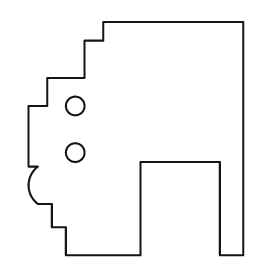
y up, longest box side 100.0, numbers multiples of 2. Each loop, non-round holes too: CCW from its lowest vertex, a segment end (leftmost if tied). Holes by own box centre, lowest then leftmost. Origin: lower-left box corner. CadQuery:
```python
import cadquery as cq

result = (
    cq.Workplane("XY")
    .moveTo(16.0, 0.0)
    .lineTo(48.0, 0.0)
    .lineTo(48.0, 40.0)
    .lineTo(82.0, 40.0)
    .lineTo(82.0, 0.0)
    .lineTo(92.0, 0.0)
    .lineTo(92.0, 100.0)
    .lineTo(32.0, 100.0)
    .lineTo(32.0, 92.0)
    .lineTo(24.0, 92.0)
    .lineTo(24.0, 76.0)
    .lineTo(8.0, 76.0)
    .lineTo(8.0, 64.0)
    .lineTo(0.0, 64.0)
    .lineTo(0.0, 38.0)
    .lineTo(4.0, 38.0)
    .threePointArc((0.0, 30.0), (4.0, 22.0))
    .lineTo(10.0, 22.0)
    .lineTo(10.0, 12.0)
    .lineTo(16.0, 12.0)
    .close()
    .moveTo(20.0, 44.0)
    .circle(4.0)
    .moveTo(20.0, 64.0)
    .circle(4.0)
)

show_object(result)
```